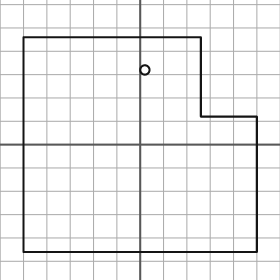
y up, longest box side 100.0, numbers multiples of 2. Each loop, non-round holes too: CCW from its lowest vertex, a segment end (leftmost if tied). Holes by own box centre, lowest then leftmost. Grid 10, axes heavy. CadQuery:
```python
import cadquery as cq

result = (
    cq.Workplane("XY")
    .moveTo(-50.0, -46.0)
    .lineTo(50.0, -46.0)
    .lineTo(50.0, 12.0)
    .lineTo(26.0, 12.0)
    .lineTo(26.0, 46.0)
    .lineTo(-50.0, 46.0)
    .close()
    .moveTo(2.0, 32.0)
    .circle(2.0)
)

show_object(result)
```